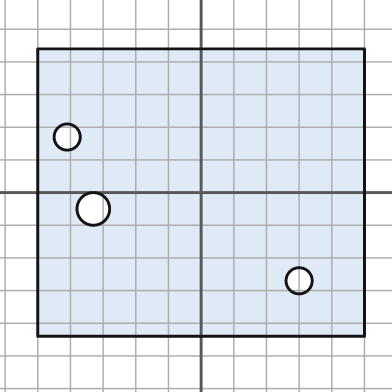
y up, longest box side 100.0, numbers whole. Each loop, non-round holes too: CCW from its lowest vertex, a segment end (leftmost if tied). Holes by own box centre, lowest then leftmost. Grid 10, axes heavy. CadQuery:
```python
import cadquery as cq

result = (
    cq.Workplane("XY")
    .moveTo(-50.0, -44.0)
    .lineTo(50.0, -44.0)
    .lineTo(50.0, 44.0)
    .lineTo(-50.0, 44.0)
    .close()
    .moveTo(30.0, -27.0)
    .circle(4.0)
    .moveTo(-33.0, -5.0)
    .circle(5.0)
    .moveTo(-41.0, 17.0)
    .circle(4.0)
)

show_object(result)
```